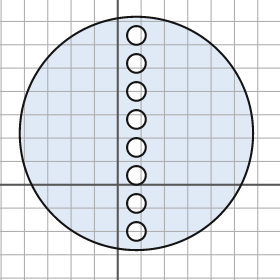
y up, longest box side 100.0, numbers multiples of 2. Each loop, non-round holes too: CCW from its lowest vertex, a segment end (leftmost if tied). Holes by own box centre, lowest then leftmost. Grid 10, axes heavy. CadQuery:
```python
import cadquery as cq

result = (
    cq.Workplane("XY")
    .moveTo(8.0, 22.0)
    .circle(50.0)
    .moveTo(8.0, -20.0)
    .circle(4.0)
    .moveTo(8.0, -8.0)
    .circle(4.0)
    .moveTo(8.0, 4.0)
    .circle(4.0)
    .moveTo(8.0, 16.0)
    .circle(4.0)
    .moveTo(8.0, 28.0)
    .circle(4.0)
    .moveTo(8.0, 40.0)
    .circle(4.0)
    .moveTo(8.0, 52.0)
    .circle(4.0)
    .moveTo(8.0, 64.0)
    .circle(4.0)
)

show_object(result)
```